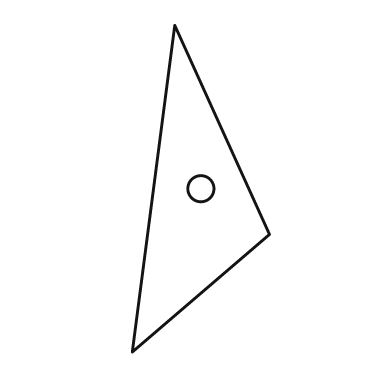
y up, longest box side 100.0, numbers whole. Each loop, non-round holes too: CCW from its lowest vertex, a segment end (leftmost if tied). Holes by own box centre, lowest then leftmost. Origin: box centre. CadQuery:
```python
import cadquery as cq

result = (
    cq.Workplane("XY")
    .moveTo(-21.0, -50.0)
    .lineTo(21.0, -14.0)
    .lineTo(-8.0, 50.0)
    .close()
    .moveTo(0.0, 0.0)
    .circle(4.0)
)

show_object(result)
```